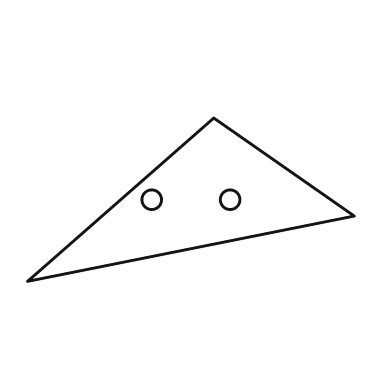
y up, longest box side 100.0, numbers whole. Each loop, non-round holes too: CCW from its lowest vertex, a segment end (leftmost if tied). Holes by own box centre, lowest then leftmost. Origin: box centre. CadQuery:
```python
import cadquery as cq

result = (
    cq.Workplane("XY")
    .moveTo(-50.0, -25.0)
    .lineTo(50.0, -5.0)
    .lineTo(7.0, 25.0)
    .close()
    .moveTo(-12.0, 0.0)
    .circle(3.0)
    .moveTo(12.0, 0.0)
    .circle(3.0)
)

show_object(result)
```